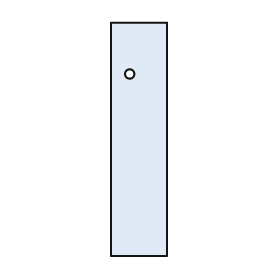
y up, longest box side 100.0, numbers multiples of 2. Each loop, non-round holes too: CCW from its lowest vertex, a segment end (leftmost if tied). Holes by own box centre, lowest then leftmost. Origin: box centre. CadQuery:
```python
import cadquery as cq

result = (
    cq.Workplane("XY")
    .moveTo(-12.0, -50.0)
    .lineTo(12.0, -50.0)
    .lineTo(12.0, 50.0)
    .lineTo(-12.0, 50.0)
    .close()
    .moveTo(-4.0, 28.0)
    .circle(2.0)
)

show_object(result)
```